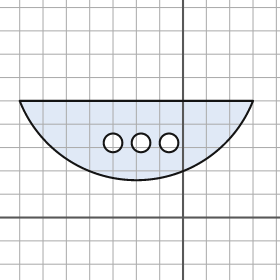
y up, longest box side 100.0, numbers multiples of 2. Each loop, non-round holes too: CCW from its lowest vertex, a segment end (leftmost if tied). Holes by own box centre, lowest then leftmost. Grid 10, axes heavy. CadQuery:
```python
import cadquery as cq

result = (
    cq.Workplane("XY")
    .moveTo(-70.0, 50.0)
    .threePointArc((-20.0, 16.0), (30.0, 50.0))
    .close()
    .moveTo(-30.0, 32.0)
    .circle(4.0)
    .moveTo(-18.0, 32.0)
    .circle(4.0)
    .moveTo(-6.0, 32.0)
    .circle(4.0)
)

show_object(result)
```